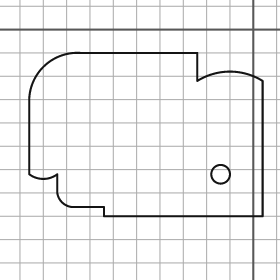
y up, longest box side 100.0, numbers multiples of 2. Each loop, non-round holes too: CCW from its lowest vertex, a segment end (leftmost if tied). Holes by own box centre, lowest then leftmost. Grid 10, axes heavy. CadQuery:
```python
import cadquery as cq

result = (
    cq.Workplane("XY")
    .moveTo(-64.0, -80.0)
    .lineTo(4.0, -80.0)
    .lineTo(4.0, -22.0)
    .threePointArc((-10.0, -18.0), (-24.0, -22.0))
    .lineTo(-24.0, -10.0)
    .lineTo(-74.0, -10.0)
    .threePointArc((-90.0, -16.0), (-96.0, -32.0))
    .lineTo(-96.0, -62.0)
    .threePointArc((-90.0, -64.0), (-84.0, -62.0))
    .lineTo(-84.0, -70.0)
    .threePointArc((-82.0, -74.0), (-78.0, -76.0))
    .lineTo(-64.0, -76.0)
    .close()
    .moveTo(-14.0, -62.0)
    .circle(4.0)
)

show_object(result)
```